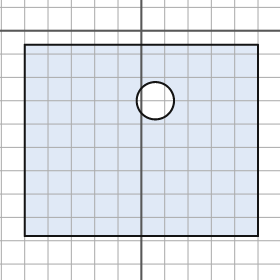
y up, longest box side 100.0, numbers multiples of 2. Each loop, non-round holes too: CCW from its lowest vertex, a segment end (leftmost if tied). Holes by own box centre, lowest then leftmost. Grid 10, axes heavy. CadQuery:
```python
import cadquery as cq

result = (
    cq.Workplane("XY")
    .moveTo(-50.0, -88.0)
    .lineTo(50.0, -88.0)
    .lineTo(50.0, -6.0)
    .lineTo(-50.0, -6.0)
    .close()
    .moveTo(6.0, -30.0)
    .circle(8.0)
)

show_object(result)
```